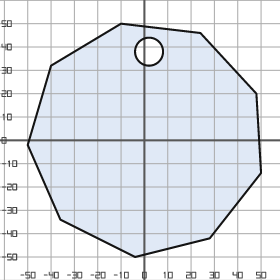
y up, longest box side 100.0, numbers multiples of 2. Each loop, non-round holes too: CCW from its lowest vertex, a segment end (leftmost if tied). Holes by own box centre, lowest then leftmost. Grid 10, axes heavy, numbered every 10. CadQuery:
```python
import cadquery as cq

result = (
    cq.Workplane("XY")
    .moveTo(-4.0, -50.0)
    .lineTo(28.0, -42.0)
    .lineTo(50.0, -14.0)
    .lineTo(48.0, 20.0)
    .lineTo(24.0, 46.0)
    .lineTo(-10.0, 50.0)
    .lineTo(-40.0, 32.0)
    .lineTo(-50.0, -2.0)
    .lineTo(-36.0, -34.0)
    .close()
    .moveTo(2.0, 38.0)
    .circle(6.0)
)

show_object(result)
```